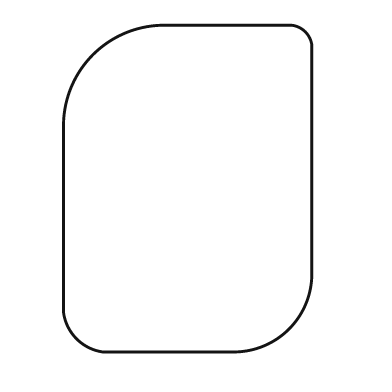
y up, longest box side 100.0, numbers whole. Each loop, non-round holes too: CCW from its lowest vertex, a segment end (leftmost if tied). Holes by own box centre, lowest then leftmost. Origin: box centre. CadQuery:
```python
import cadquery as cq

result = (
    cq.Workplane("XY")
    .moveTo(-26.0, -50.0)
    .lineTo(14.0, -50.0)
    .threePointArc((31.0, -43.0), (38.0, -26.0))
    .lineTo(38.0, 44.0)
    .threePointArc((36.0, 48.0), (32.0, 50.0))
    .lineTo(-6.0, 50.0)
    .threePointArc((-29.0, 41.0), (-38.0, 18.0))
    .lineTo(-38.0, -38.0)
    .threePointArc((-34.0, -46.0), (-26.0, -50.0))
    .close()
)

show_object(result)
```